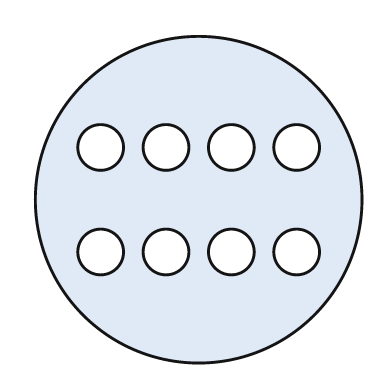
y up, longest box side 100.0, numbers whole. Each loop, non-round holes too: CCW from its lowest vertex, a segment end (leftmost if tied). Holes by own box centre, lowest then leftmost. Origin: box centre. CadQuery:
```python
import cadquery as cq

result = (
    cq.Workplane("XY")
    .moveTo(0.0, 0.0)
    .circle(50.0)
    .moveTo(-30.0, -16.0)
    .circle(7.0)
    .moveTo(-10.0, -16.0)
    .circle(7.0)
    .moveTo(10.0, -16.0)
    .circle(7.0)
    .moveTo(30.0, -16.0)
    .circle(7.0)
    .moveTo(-30.0, 16.0)
    .circle(7.0)
    .moveTo(-10.0, 16.0)
    .circle(7.0)
    .moveTo(10.0, 16.0)
    .circle(7.0)
    .moveTo(30.0, 16.0)
    .circle(7.0)
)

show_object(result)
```